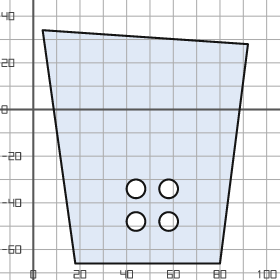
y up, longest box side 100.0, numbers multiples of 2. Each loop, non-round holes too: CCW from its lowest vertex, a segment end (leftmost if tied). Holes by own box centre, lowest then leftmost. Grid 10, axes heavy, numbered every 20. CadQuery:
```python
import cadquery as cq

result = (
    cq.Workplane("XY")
    .moveTo(18.0, -66.0)
    .lineTo(80.0, -66.0)
    .lineTo(92.0, 28.0)
    .lineTo(4.0, 34.0)
    .close()
    .moveTo(44.0, -48.0)
    .circle(4.0)
    .moveTo(58.0, -48.0)
    .circle(4.0)
    .moveTo(44.0, -34.0)
    .circle(4.0)
    .moveTo(58.0, -34.0)
    .circle(4.0)
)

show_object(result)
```